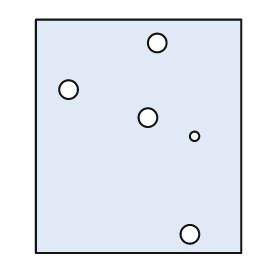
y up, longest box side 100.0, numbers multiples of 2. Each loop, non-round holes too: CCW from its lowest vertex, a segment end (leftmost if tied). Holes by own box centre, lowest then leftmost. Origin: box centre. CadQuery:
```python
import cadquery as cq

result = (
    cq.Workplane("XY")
    .moveTo(-44.0, -50.0)
    .lineTo(44.0, -50.0)
    .lineTo(44.0, 50.0)
    .lineTo(-44.0, 50.0)
    .close()
    .moveTo(22.0, -42.0)
    .circle(4.0)
    .moveTo(24.0, 0.0)
    .circle(2.0)
    .moveTo(4.0, 8.0)
    .circle(4.0)
    .moveTo(-30.0, 20.0)
    .circle(4.0)
    .moveTo(8.0, 40.0)
    .circle(4.0)
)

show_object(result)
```